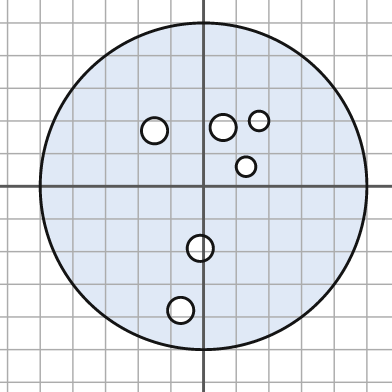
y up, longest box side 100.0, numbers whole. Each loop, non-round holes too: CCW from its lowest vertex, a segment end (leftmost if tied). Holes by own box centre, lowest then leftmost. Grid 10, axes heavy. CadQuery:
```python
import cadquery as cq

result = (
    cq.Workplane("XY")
    .moveTo(0.0, 0.0)
    .circle(50.0)
    .moveTo(-7.0, -38.0)
    .circle(4.0)
    .moveTo(-1.0, -19.0)
    .circle(4.0)
    .moveTo(13.0, 6.0)
    .circle(3.0)
    .moveTo(-15.0, 17.0)
    .circle(4.0)
    .moveTo(6.0, 18.0)
    .circle(4.0)
    .moveTo(17.0, 20.0)
    .circle(3.0)
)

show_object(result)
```